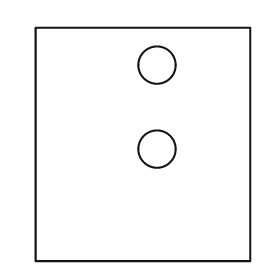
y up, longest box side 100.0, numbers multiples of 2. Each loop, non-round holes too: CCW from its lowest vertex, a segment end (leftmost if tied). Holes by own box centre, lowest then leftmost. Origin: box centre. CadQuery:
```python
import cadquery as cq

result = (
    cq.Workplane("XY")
    .moveTo(-46.0, -50.0)
    .lineTo(46.0, -50.0)
    .lineTo(46.0, 50.0)
    .lineTo(-46.0, 50.0)
    .close()
    .moveTo(6.0, -2.0)
    .circle(8.0)
    .moveTo(6.0, 34.0)
    .circle(8.0)
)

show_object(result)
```